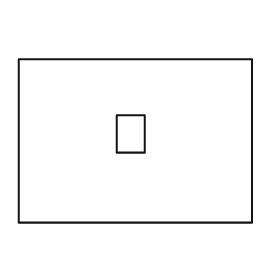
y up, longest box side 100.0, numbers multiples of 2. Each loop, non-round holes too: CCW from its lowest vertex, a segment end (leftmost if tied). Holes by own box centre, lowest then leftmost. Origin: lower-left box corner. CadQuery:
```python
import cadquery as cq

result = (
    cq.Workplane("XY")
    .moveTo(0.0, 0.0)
    .lineTo(100.0, 0.0)
    .lineTo(100.0, 70.0)
    .lineTo(0.0, 70.0)
    .close()
    .moveTo(42.0, 30.0)
    .lineTo(54.0, 30.0)
    .lineTo(54.0, 46.0)
    .lineTo(42.0, 46.0)
    .close()
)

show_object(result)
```